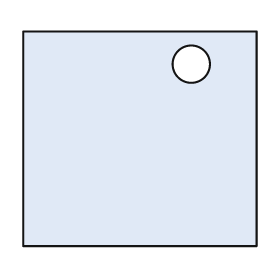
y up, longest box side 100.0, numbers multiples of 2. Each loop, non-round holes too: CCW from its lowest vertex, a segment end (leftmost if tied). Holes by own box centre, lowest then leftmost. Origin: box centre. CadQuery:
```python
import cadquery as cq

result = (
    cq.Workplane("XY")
    .moveTo(-50.0, -46.0)
    .lineTo(50.0, -46.0)
    .lineTo(50.0, 46.0)
    .lineTo(-50.0, 46.0)
    .close()
    .moveTo(22.0, 32.0)
    .circle(8.0)
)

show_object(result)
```